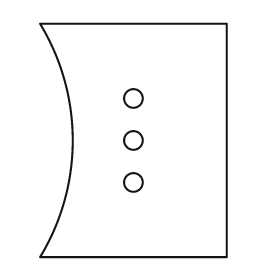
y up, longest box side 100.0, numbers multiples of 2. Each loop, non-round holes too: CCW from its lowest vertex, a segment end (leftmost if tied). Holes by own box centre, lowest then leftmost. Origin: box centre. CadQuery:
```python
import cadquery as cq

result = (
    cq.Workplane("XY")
    .moveTo(-40.0, -50.0)
    .lineTo(40.0, -50.0)
    .lineTo(40.0, 50.0)
    .lineTo(-40.0, 50.0)
    .threePointArc((-26.0, 0.0), (-40.0, -50.0))
    .close()
    .moveTo(0.0, -18.0)
    .circle(4.0)
    .moveTo(0.0, 0.0)
    .circle(4.0)
    .moveTo(0.0, 18.0)
    .circle(4.0)
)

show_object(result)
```